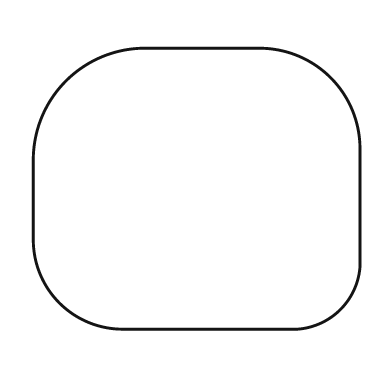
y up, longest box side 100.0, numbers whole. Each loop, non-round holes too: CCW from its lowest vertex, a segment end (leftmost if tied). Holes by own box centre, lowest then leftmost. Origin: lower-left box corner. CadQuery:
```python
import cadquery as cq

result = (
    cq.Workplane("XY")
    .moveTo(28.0, 0.0)
    .lineTo(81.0, 0.0)
    .threePointArc((94.0, 6.0), (100.0, 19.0))
    .lineTo(100.0, 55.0)
    .threePointArc((91.0, 77.0), (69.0, 86.0))
    .lineTo(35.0, 86.0)
    .threePointArc((10.0, 76.0), (0.0, 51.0))
    .lineTo(0.0, 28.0)
    .threePointArc((8.0, 8.0), (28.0, 0.0))
    .close()
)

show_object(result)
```